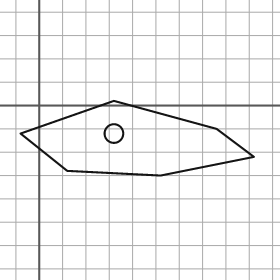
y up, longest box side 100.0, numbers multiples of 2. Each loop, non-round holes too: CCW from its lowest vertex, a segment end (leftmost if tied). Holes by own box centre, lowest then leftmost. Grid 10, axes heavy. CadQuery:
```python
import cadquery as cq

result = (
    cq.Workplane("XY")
    .moveTo(52.0, -30.0)
    .lineTo(92.0, -22.0)
    .lineTo(76.0, -10.0)
    .lineTo(32.0, 2.0)
    .lineTo(-8.0, -12.0)
    .lineTo(12.0, -28.0)
    .close()
    .moveTo(32.0, -12.0)
    .circle(4.0)
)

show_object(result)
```